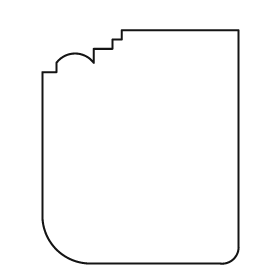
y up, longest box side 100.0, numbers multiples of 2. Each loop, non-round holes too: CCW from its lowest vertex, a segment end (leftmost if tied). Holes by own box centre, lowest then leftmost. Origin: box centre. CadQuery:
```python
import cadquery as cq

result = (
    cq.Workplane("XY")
    .moveTo(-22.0, -50.0)
    .lineTo(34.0, -50.0)
    .threePointArc((40.0, -48.0), (42.0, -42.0))
    .lineTo(42.0, 50.0)
    .lineTo(-8.0, 50.0)
    .lineTo(-8.0, 46.0)
    .lineTo(-12.0, 46.0)
    .lineTo(-12.0, 42.0)
    .lineTo(-20.0, 42.0)
    .lineTo(-20.0, 36.0)
    .threePointArc((-28.0, 40.0), (-36.0, 36.0))
    .lineTo(-36.0, 32.0)
    .lineTo(-42.0, 32.0)
    .lineTo(-42.0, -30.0)
    .threePointArc((-36.0, -44.0), (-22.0, -50.0))
    .close()
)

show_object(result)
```